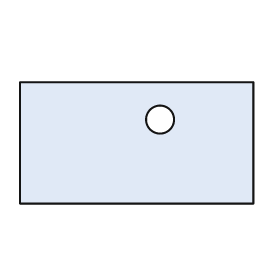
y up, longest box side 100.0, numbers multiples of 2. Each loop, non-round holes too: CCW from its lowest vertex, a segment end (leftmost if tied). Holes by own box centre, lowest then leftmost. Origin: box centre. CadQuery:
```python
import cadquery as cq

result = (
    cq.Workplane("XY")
    .moveTo(-50.0, -26.0)
    .lineTo(50.0, -26.0)
    .lineTo(50.0, 26.0)
    .lineTo(-50.0, 26.0)
    .close()
    .moveTo(10.0, 10.0)
    .circle(6.0)
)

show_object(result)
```